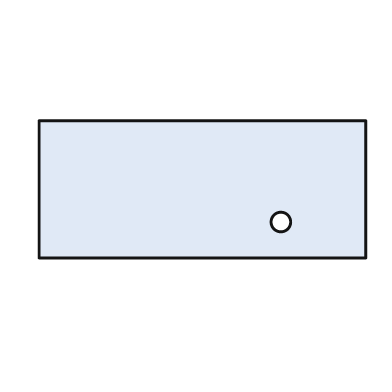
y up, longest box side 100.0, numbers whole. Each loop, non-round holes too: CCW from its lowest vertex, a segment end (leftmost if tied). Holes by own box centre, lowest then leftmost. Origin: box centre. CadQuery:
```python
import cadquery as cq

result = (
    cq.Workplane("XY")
    .moveTo(-50.0, -21.0)
    .lineTo(50.0, -21.0)
    .lineTo(50.0, 21.0)
    .lineTo(-50.0, 21.0)
    .close()
    .moveTo(24.0, -10.0)
    .circle(3.0)
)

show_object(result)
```